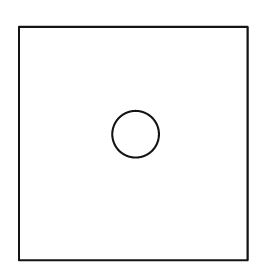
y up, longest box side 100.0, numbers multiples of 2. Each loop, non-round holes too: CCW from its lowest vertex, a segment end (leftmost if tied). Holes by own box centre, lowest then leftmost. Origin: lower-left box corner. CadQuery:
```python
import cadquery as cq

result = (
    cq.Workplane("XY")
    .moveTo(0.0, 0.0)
    .lineTo(98.0, 0.0)
    .lineTo(98.0, 100.0)
    .lineTo(0.0, 100.0)
    .close()
    .moveTo(50.0, 54.0)
    .circle(10.0)
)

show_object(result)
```